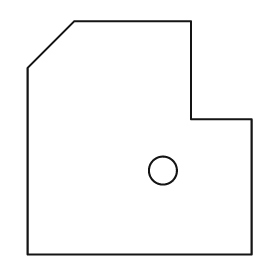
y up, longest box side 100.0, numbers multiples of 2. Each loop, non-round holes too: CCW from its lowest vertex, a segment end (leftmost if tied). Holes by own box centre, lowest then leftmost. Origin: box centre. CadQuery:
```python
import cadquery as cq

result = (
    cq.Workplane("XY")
    .moveTo(-48.0, -50.0)
    .lineTo(48.0, -50.0)
    .lineTo(48.0, 8.0)
    .lineTo(22.0, 8.0)
    .lineTo(22.0, 50.0)
    .lineTo(-28.0, 50.0)
    .lineTo(-48.0, 30.0)
    .close()
    .moveTo(10.0, -14.0)
    .circle(6.0)
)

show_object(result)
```